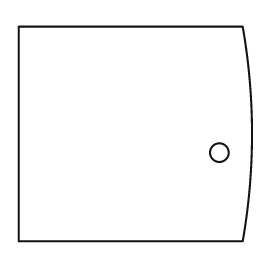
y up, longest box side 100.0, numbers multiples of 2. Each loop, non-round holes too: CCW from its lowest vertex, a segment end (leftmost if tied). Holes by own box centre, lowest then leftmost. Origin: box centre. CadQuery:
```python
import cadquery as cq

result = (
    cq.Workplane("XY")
    .moveTo(-50.0, -46.0)
    .lineTo(46.0, -46.0)
    .threePointArc((50.0, 0.0), (46.0, 46.0))
    .lineTo(-50.0, 46.0)
    .close()
    .moveTo(36.0, -8.0)
    .circle(4.0)
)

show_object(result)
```